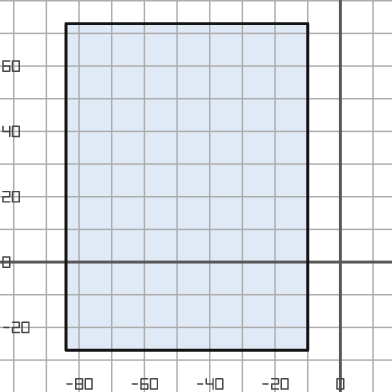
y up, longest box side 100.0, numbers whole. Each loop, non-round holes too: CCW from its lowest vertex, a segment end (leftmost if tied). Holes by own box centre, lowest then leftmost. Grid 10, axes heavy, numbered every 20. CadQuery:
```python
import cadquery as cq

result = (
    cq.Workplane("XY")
    .moveTo(-84.0, -27.0)
    .lineTo(-10.0, -27.0)
    .lineTo(-10.0, 73.0)
    .lineTo(-84.0, 73.0)
    .close()
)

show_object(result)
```